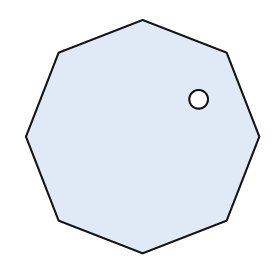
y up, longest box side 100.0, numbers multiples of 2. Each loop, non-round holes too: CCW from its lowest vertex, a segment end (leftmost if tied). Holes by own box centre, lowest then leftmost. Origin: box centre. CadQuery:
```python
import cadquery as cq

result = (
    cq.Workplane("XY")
    .moveTo(0.0, -50.0)
    .lineTo(36.0, -36.0)
    .lineTo(50.0, 0.0)
    .lineTo(36.0, 36.0)
    .lineTo(0.0, 50.0)
    .lineTo(-36.0, 36.0)
    .lineTo(-50.0, 0.0)
    .lineTo(-36.0, -36.0)
    .close()
    .moveTo(24.0, 16.0)
    .circle(4.0)
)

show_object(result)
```